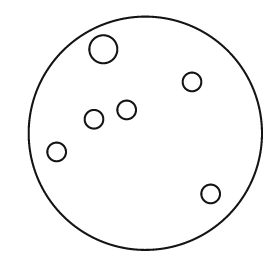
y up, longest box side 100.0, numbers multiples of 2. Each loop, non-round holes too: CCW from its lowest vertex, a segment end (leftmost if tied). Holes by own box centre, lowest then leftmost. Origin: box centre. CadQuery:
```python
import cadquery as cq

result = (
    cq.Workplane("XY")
    .moveTo(0.0, 0.0)
    .circle(50.0)
    .moveTo(28.0, -26.0)
    .circle(4.0)
    .moveTo(-38.0, -8.0)
    .circle(4.0)
    .moveTo(-22.0, 6.0)
    .circle(4.0)
    .moveTo(-8.0, 10.0)
    .circle(4.0)
    .moveTo(20.0, 22.0)
    .circle(4.0)
    .moveTo(-18.0, 36.0)
    .circle(6.0)
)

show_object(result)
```